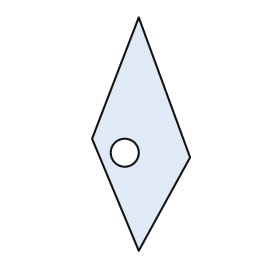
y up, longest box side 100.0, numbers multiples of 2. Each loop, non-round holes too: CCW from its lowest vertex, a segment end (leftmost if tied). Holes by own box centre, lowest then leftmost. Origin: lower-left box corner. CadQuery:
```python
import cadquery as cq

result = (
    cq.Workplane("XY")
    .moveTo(20.0, 0.0)
    .lineTo(42.0, 40.0)
    .lineTo(20.0, 100.0)
    .lineTo(0.0, 48.0)
    .close()
    .moveTo(14.0, 42.0)
    .circle(6.0)
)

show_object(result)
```